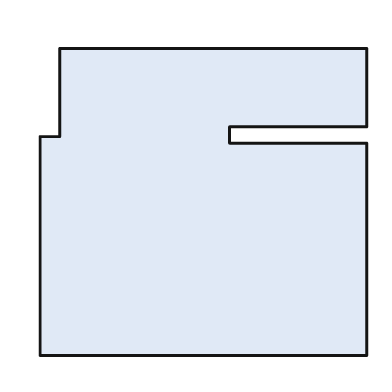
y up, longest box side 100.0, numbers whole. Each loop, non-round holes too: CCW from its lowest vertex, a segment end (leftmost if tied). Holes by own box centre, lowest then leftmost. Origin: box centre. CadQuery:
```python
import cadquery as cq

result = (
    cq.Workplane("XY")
    .moveTo(-50.0, -47.0)
    .lineTo(50.0, -47.0)
    .lineTo(50.0, 18.0)
    .lineTo(8.0, 18.0)
    .lineTo(8.0, 23.0)
    .lineTo(50.0, 23.0)
    .lineTo(50.0, 47.0)
    .lineTo(-44.0, 47.0)
    .lineTo(-44.0, 20.0)
    .lineTo(-50.0, 20.0)
    .close()
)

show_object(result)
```